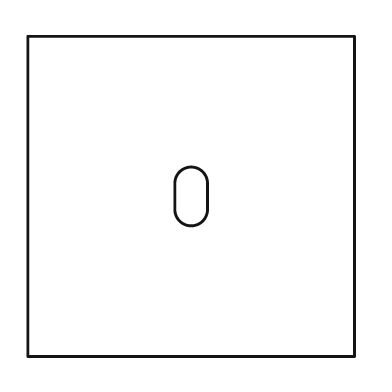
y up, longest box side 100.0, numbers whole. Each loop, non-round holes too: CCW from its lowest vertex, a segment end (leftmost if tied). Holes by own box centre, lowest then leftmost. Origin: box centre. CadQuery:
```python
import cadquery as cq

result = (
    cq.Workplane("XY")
    .moveTo(-50.0, -49.0)
    .lineTo(50.0, -49.0)
    .lineTo(50.0, 49.0)
    .lineTo(-50.0, 49.0)
    .close()
    .moveTo(-5.0, -4.0)
    .threePointArc((0.0, -9.0), (5.0, -4.0))
    .lineTo(5.0, 4.0)
    .threePointArc((0.0, 9.0), (-5.0, 4.0))
    .close()
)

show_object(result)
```